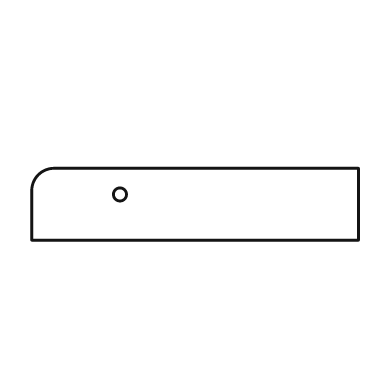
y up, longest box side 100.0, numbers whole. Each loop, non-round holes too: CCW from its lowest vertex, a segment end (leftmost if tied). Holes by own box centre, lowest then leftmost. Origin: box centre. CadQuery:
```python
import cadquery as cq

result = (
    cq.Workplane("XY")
    .moveTo(-50.0, -11.0)
    .lineTo(50.0, -11.0)
    .lineTo(50.0, 11.0)
    .lineTo(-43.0, 11.0)
    .threePointArc((-48.0, 9.0), (-50.0, 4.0))
    .close()
    .moveTo(-23.0, 3.0)
    .circle(2.0)
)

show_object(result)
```